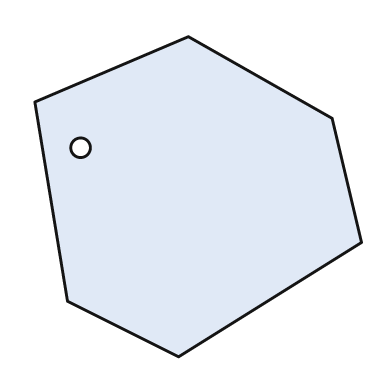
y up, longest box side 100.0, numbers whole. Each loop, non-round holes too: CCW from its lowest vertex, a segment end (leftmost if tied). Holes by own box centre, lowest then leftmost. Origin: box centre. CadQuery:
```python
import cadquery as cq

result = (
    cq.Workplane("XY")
    .moveTo(-6.0, -49.0)
    .lineTo(50.0, -14.0)
    .lineTo(41.0, 24.0)
    .lineTo(-3.0, 49.0)
    .lineTo(-50.0, 29.0)
    .lineTo(-40.0, -32.0)
    .close()
    .moveTo(-36.0, 15.0)
    .circle(3.0)
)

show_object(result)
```